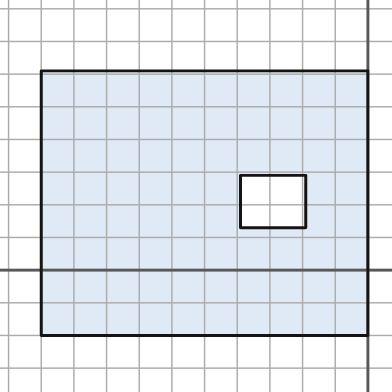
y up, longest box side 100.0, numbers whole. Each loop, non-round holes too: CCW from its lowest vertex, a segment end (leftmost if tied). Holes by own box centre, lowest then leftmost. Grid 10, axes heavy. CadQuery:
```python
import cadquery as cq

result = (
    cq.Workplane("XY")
    .moveTo(-100.0, -20.0)
    .lineTo(0.0, -20.0)
    .lineTo(0.0, 61.0)
    .lineTo(-100.0, 61.0)
    .close()
    .moveTo(-39.0, 13.0)
    .lineTo(-19.0, 13.0)
    .lineTo(-19.0, 29.0)
    .lineTo(-39.0, 29.0)
    .close()
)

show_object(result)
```